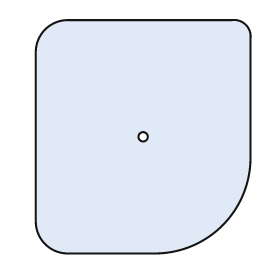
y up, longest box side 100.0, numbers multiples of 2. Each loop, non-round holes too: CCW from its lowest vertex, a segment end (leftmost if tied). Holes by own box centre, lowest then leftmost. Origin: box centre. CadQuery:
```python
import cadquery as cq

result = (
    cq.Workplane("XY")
    .moveTo(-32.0, -50.0)
    .lineTo(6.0, -50.0)
    .threePointArc((34.0, -38.0), (46.0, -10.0))
    .lineTo(46.0, 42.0)
    .threePointArc((44.0, 48.0), (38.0, 50.0))
    .lineTo(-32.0, 50.0)
    .threePointArc((-42.0, 46.0), (-46.0, 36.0))
    .lineTo(-46.0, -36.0)
    .threePointArc((-42.0, -46.0), (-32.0, -50.0))
    .close()
    .moveTo(0.0, 0.0)
    .circle(2.0)
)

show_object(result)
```